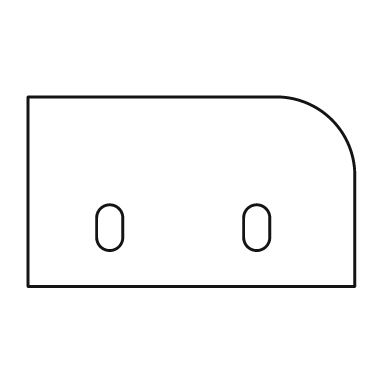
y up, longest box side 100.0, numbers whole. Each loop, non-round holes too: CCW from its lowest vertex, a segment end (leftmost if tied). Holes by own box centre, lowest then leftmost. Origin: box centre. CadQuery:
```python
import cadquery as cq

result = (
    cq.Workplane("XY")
    .moveTo(-50.0, -29.0)
    .lineTo(50.0, -29.0)
    .lineTo(50.0, 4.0)
    .threePointArc((43.0, 22.0), (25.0, 29.0))
    .lineTo(-50.0, 29.0)
    .close()
    .moveTo(-29.0, -14.0)
    .threePointArc((-25.0, -18.0), (-21.0, -14.0))
    .lineTo(-21.0, -8.0)
    .threePointArc((-25.0, -4.0), (-29.0, -8.0))
    .close()
    .moveTo(16.0, -14.0)
    .threePointArc((20.0, -18.0), (24.0, -14.0))
    .lineTo(24.0, -8.0)
    .threePointArc((20.0, -4.0), (16.0, -8.0))
    .close()
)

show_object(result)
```